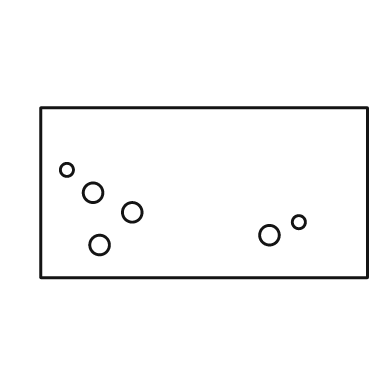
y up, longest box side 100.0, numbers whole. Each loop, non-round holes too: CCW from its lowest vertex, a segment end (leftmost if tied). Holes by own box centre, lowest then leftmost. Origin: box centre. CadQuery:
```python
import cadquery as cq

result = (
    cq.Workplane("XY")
    .moveTo(-50.0, -26.0)
    .lineTo(50.0, -26.0)
    .lineTo(50.0, 26.0)
    .lineTo(-50.0, 26.0)
    .close()
    .moveTo(-32.0, -16.0)
    .circle(3.0)
    .moveTo(20.0, -13.0)
    .circle(3.0)
    .moveTo(29.0, -9.0)
    .circle(2.0)
    .moveTo(-22.0, -6.0)
    .circle(3.0)
    .moveTo(-34.0, 0.0)
    .circle(3.0)
    .moveTo(-42.0, 7.0)
    .circle(2.0)
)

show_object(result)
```